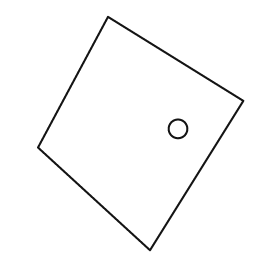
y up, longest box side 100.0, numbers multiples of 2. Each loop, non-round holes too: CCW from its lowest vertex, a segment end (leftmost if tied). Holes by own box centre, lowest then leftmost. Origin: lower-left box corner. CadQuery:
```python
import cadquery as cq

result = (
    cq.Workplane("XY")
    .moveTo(48.0, 0.0)
    .lineTo(88.0, 64.0)
    .lineTo(30.0, 100.0)
    .lineTo(0.0, 44.0)
    .close()
    .moveTo(60.0, 52.0)
    .circle(4.0)
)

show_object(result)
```